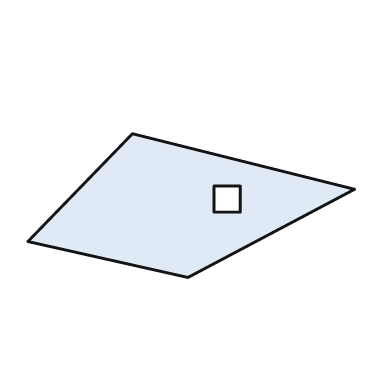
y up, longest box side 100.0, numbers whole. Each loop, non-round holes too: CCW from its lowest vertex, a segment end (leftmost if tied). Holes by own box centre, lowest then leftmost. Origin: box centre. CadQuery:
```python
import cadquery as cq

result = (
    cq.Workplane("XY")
    .moveTo(-1.0, -22.0)
    .lineTo(50.0, 5.0)
    .lineTo(-18.0, 22.0)
    .lineTo(-50.0, -11.0)
    .close()
    .moveTo(7.0, -2.0)
    .lineTo(15.0, -2.0)
    .lineTo(15.0, 6.0)
    .lineTo(7.0, 6.0)
    .close()
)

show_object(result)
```